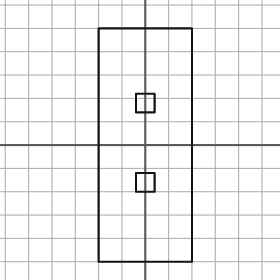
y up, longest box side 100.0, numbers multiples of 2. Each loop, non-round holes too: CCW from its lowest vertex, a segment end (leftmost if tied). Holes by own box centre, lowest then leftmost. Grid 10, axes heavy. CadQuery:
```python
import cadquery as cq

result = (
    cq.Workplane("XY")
    .moveTo(-20.0, -50.0)
    .lineTo(20.0, -50.0)
    .lineTo(20.0, 50.0)
    .lineTo(-20.0, 50.0)
    .close()
    .moveTo(-4.0, -20.0)
    .lineTo(4.0, -20.0)
    .lineTo(4.0, -12.0)
    .lineTo(-4.0, -12.0)
    .close()
    .moveTo(-4.0, 14.0)
    .lineTo(4.0, 14.0)
    .lineTo(4.0, 22.0)
    .lineTo(-4.0, 22.0)
    .close()
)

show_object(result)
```